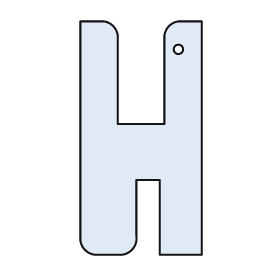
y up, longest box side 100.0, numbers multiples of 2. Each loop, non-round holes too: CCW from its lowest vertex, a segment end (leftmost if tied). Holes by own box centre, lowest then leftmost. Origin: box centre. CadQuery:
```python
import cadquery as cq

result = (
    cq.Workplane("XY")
    .moveTo(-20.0, -50.0)
    .lineTo(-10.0, -50.0)
    .threePointArc((-4.0, -48.0), (-2.0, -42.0))
    .lineTo(-2.0, -18.0)
    .lineTo(8.0, -18.0)
    .lineTo(8.0, -50.0)
    .lineTo(26.0, -50.0)
    .lineTo(26.0, 50.0)
    .lineTo(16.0, 50.0)
    .threePointArc((12.0, 48.0), (10.0, 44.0))
    .lineTo(10.0, 6.0)
    .lineTo(-10.0, 6.0)
    .lineTo(-10.0, 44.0)
    .threePointArc((-12.0, 48.0), (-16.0, 50.0))
    .lineTo(-26.0, 50.0)
    .lineTo(-26.0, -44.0)
    .threePointArc((-24.0, -48.0), (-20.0, -50.0))
    .close()
    .moveTo(16.0, 38.0)
    .circle(2.0)
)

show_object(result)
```